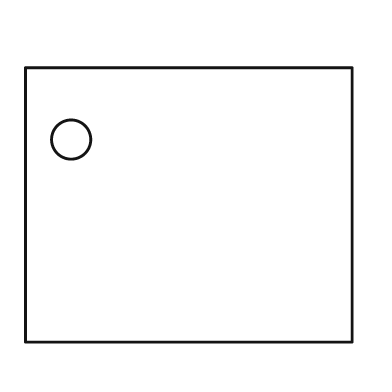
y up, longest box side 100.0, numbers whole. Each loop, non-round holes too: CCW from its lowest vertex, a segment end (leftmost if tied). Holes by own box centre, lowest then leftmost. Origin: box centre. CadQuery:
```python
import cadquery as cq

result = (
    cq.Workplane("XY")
    .moveTo(-50.0, -42.0)
    .lineTo(50.0, -42.0)
    .lineTo(50.0, 42.0)
    .lineTo(-50.0, 42.0)
    .close()
    .moveTo(-36.0, 20.0)
    .circle(6.0)
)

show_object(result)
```